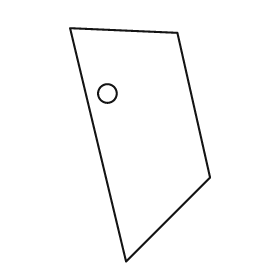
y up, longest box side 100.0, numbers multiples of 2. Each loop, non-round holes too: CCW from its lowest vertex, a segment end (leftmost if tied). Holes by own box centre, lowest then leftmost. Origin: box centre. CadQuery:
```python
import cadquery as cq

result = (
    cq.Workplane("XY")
    .moveTo(-6.0, -50.0)
    .lineTo(30.0, -14.0)
    .lineTo(16.0, 48.0)
    .lineTo(-30.0, 50.0)
    .close()
    .moveTo(-14.0, 22.0)
    .circle(4.0)
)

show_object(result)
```